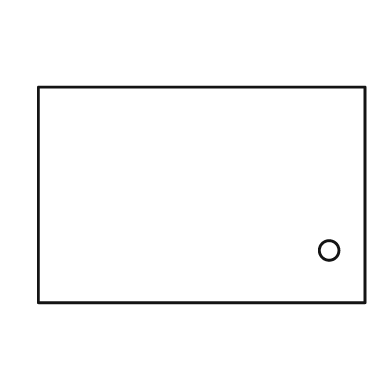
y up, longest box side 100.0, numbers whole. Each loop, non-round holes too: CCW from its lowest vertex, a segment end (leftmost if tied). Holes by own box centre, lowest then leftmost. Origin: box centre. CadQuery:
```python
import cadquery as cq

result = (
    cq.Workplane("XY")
    .moveTo(-50.0, -33.0)
    .lineTo(50.0, -33.0)
    .lineTo(50.0, 33.0)
    .lineTo(-50.0, 33.0)
    .close()
    .moveTo(39.0, -17.0)
    .circle(3.0)
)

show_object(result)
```